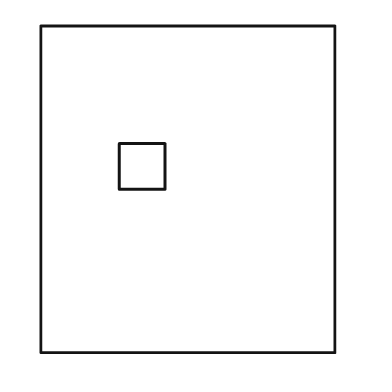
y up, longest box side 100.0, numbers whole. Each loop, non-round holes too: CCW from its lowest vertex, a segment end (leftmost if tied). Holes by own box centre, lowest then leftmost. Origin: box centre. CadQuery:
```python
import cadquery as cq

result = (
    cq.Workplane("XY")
    .moveTo(-45.0, -50.0)
    .lineTo(45.0, -50.0)
    .lineTo(45.0, 50.0)
    .lineTo(-45.0, 50.0)
    .close()
    .moveTo(-21.0, 0.0)
    .lineTo(-7.0, 0.0)
    .lineTo(-7.0, 14.0)
    .lineTo(-21.0, 14.0)
    .close()
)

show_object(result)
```